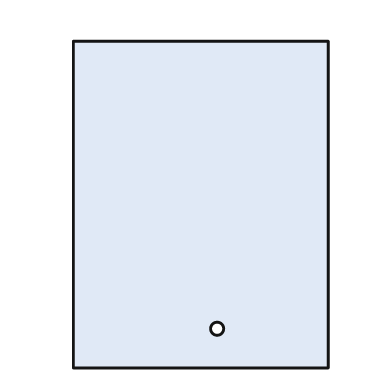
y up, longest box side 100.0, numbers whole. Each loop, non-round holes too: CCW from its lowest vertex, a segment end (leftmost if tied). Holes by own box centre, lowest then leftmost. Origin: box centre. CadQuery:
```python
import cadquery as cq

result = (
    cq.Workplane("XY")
    .moveTo(-39.0, -50.0)
    .lineTo(39.0, -50.0)
    .lineTo(39.0, 50.0)
    .lineTo(-39.0, 50.0)
    .close()
    .moveTo(5.0, -38.0)
    .circle(2.0)
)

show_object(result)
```